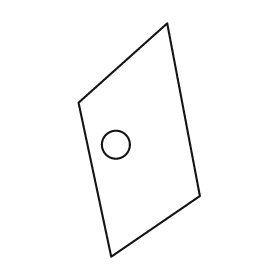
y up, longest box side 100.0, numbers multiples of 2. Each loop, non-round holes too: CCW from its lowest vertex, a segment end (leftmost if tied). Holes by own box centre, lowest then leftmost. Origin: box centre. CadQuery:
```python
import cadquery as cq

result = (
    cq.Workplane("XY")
    .moveTo(-12.0, -50.0)
    .lineTo(26.0, -24.0)
    .lineTo(12.0, 50.0)
    .lineTo(-26.0, 16.0)
    .close()
    .moveTo(-10.0, -2.0)
    .circle(6.0)
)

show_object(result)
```